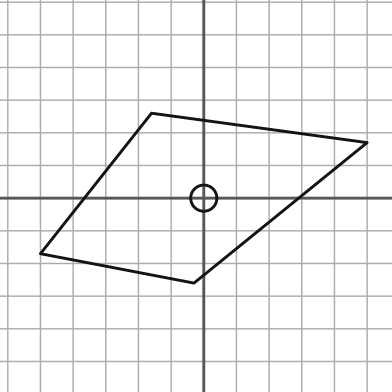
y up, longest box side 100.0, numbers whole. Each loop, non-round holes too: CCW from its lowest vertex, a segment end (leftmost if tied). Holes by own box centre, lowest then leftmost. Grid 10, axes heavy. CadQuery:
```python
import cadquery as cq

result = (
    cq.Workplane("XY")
    .moveTo(-3.0, -26.0)
    .lineTo(50.0, 17.0)
    .lineTo(-16.0, 26.0)
    .lineTo(-50.0, -17.0)
    .close()
    .moveTo(0.0, 0.0)
    .circle(4.0)
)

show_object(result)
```